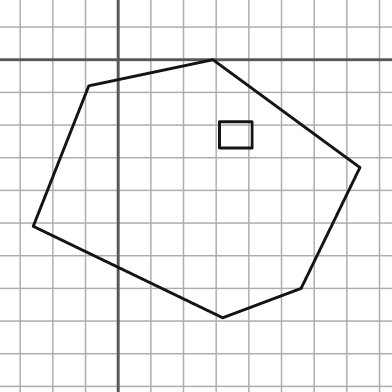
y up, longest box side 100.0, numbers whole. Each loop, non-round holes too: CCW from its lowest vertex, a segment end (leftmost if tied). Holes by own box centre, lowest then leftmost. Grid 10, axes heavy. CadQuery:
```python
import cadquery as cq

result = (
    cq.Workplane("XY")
    .moveTo(32.0, -79.0)
    .lineTo(56.0, -70.0)
    .lineTo(74.0, -33.0)
    .lineTo(29.0, 0.0)
    .lineTo(-9.0, -8.0)
    .lineTo(-26.0, -51.0)
    .close()
    .moveTo(31.0, -27.0)
    .lineTo(41.0, -27.0)
    .lineTo(41.0, -19.0)
    .lineTo(31.0, -19.0)
    .close()
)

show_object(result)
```